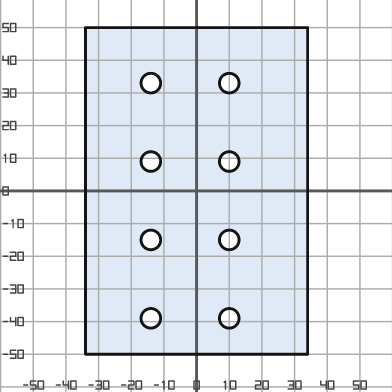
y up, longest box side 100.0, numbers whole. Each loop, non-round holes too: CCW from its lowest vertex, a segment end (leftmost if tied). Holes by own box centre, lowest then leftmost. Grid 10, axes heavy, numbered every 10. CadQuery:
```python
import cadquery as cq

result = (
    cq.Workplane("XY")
    .moveTo(-34.0, -50.0)
    .lineTo(34.0, -50.0)
    .lineTo(34.0, 50.0)
    .lineTo(-34.0, 50.0)
    .close()
    .moveTo(-14.0, -39.0)
    .circle(3.0)
    .moveTo(10.0, -39.0)
    .circle(3.0)
    .moveTo(-14.0, -15.0)
    .circle(3.0)
    .moveTo(10.0, -15.0)
    .circle(3.0)
    .moveTo(-14.0, 9.0)
    .circle(3.0)
    .moveTo(10.0, 9.0)
    .circle(3.0)
    .moveTo(-14.0, 33.0)
    .circle(3.0)
    .moveTo(10.0, 33.0)
    .circle(3.0)
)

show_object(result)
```